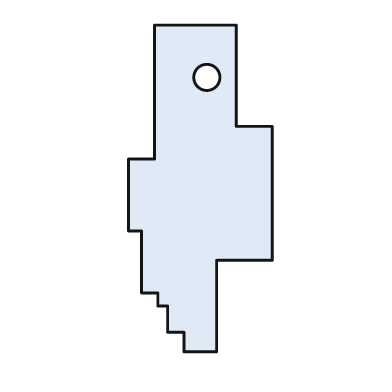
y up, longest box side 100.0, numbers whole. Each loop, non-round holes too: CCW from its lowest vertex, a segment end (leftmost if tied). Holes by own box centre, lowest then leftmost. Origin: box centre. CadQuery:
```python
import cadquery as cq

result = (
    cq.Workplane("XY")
    .moveTo(-5.0, -50.0)
    .lineTo(5.0, -50.0)
    .lineTo(5.0, -22.0)
    .lineTo(22.0, -22.0)
    .lineTo(22.0, 19.0)
    .lineTo(11.0, 19.0)
    .lineTo(11.0, 50.0)
    .lineTo(-14.0, 50.0)
    .lineTo(-14.0, 9.0)
    .lineTo(-22.0, 9.0)
    .lineTo(-22.0, -13.0)
    .lineTo(-18.0, -13.0)
    .lineTo(-18.0, -32.0)
    .lineTo(-13.0, -32.0)
    .lineTo(-13.0, -36.0)
    .lineTo(-10.0, -36.0)
    .lineTo(-10.0, -44.0)
    .lineTo(-5.0, -44.0)
    .close()
    .moveTo(2.0, 34.0)
    .circle(4.0)
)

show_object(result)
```